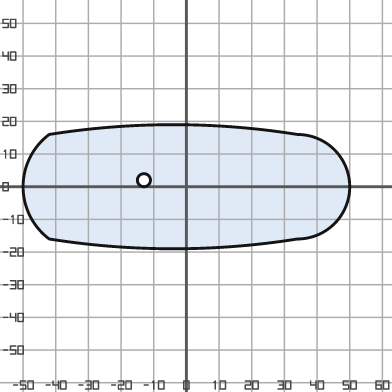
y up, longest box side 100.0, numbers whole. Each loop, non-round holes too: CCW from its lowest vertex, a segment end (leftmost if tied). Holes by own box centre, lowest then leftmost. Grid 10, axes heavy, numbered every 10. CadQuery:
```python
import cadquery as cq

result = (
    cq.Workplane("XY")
    .moveTo(-42.0, -16.0)
    .threePointArc((-4.0, -19.0), (34.0, -16.0))
    .threePointArc((50.0, 0.0), (34.0, 16.0))
    .threePointArc((-4.0, 19.0), (-42.0, 16.0))
    .threePointArc((-50.0, 0.0), (-42.0, -16.0))
    .close()
    .moveTo(-13.0, 2.0)
    .circle(2.0)
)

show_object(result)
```